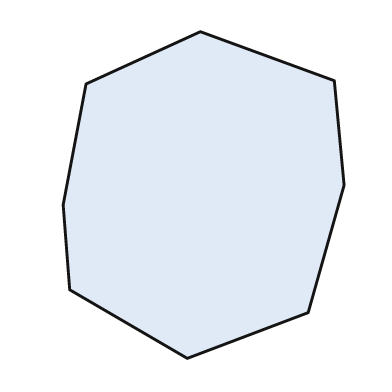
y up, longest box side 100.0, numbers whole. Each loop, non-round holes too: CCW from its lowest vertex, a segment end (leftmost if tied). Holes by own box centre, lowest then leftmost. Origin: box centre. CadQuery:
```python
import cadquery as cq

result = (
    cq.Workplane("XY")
    .moveTo(-5.0, -50.0)
    .lineTo(32.0, -36.0)
    .lineTo(43.0, 3.0)
    .lineTo(40.0, 35.0)
    .lineTo(-1.0, 50.0)
    .lineTo(-36.0, 34.0)
    .lineTo(-43.0, -3.0)
    .lineTo(-41.0, -29.0)
    .close()
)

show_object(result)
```